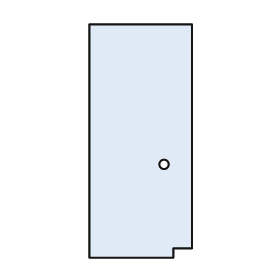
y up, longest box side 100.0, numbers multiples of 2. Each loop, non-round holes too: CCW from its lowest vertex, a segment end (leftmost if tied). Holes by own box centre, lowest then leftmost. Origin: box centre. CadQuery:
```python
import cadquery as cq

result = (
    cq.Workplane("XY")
    .moveTo(-22.0, -50.0)
    .lineTo(14.0, -50.0)
    .lineTo(14.0, -46.0)
    .lineTo(22.0, -46.0)
    .lineTo(22.0, 50.0)
    .lineTo(-22.0, 50.0)
    .close()
    .moveTo(10.0, -10.0)
    .circle(2.0)
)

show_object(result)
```